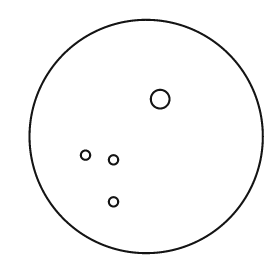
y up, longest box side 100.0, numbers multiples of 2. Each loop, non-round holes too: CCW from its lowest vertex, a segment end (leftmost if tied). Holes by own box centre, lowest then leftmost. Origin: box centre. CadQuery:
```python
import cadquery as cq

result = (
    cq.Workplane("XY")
    .moveTo(0.0, 0.0)
    .circle(50.0)
    .moveTo(-14.0, -28.0)
    .circle(2.0)
    .moveTo(-14.0, -10.0)
    .circle(2.0)
    .moveTo(-26.0, -8.0)
    .circle(2.0)
    .moveTo(6.0, 16.0)
    .circle(4.0)
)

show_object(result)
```